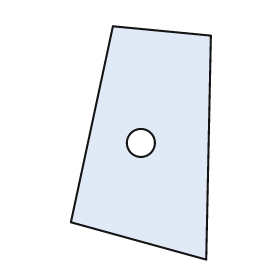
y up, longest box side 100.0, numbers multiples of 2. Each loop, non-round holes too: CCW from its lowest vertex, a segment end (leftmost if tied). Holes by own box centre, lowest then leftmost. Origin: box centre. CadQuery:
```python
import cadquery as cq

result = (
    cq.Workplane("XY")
    .moveTo(28.0, -50.0)
    .lineTo(30.0, 46.0)
    .lineTo(-12.0, 50.0)
    .lineTo(-30.0, -34.0)
    .close()
    .moveTo(0.0, 0.0)
    .circle(6.0)
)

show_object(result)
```